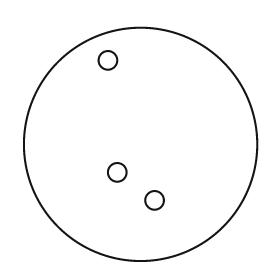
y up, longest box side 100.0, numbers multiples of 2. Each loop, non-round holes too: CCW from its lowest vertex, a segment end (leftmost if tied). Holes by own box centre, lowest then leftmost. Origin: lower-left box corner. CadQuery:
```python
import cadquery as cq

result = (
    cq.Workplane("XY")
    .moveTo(50.0, 50.0)
    .circle(50.0)
    .moveTo(56.0, 26.0)
    .circle(4.0)
    .moveTo(40.0, 38.0)
    .circle(4.0)
    .moveTo(36.0, 86.0)
    .circle(4.0)
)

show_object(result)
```